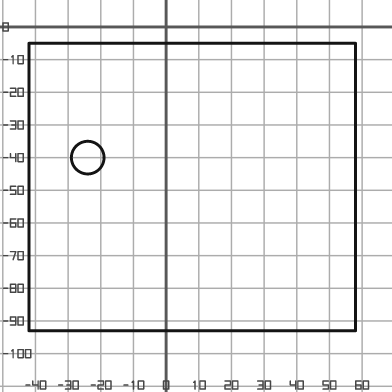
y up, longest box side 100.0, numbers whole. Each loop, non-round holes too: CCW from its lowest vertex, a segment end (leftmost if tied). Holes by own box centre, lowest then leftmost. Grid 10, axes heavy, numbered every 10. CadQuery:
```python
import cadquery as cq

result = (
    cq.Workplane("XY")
    .moveTo(-42.0, -93.0)
    .lineTo(58.0, -93.0)
    .lineTo(58.0, -5.0)
    .lineTo(-42.0, -5.0)
    .close()
    .moveTo(-24.0, -40.0)
    .circle(5.0)
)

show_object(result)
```